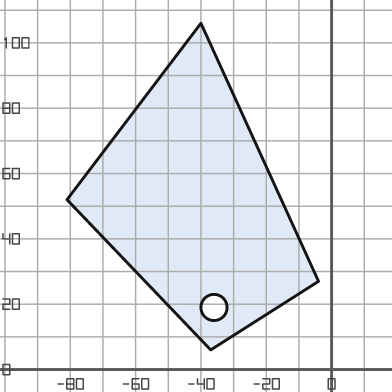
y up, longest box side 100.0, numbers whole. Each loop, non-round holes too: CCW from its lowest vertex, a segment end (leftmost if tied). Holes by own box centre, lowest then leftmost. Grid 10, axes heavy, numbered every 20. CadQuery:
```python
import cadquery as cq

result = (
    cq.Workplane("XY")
    .moveTo(-37.0, 6.0)
    .lineTo(-4.0, 27.0)
    .lineTo(-40.0, 106.0)
    .lineTo(-81.0, 52.0)
    .close()
    .moveTo(-36.0, 19.0)
    .circle(4.0)
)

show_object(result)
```